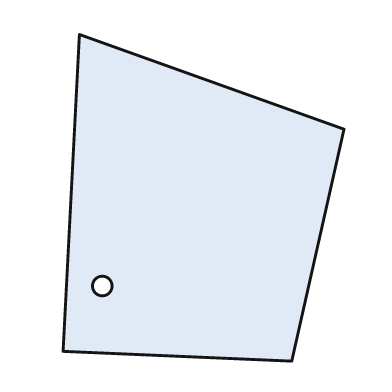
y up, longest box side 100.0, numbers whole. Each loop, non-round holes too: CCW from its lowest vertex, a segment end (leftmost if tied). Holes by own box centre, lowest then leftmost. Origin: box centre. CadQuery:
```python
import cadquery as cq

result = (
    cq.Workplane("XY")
    .moveTo(27.0, -50.0)
    .lineTo(43.0, 21.0)
    .lineTo(-38.0, 50.0)
    .lineTo(-43.0, -47.0)
    .close()
    .moveTo(-31.0, -27.0)
    .circle(3.0)
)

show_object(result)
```